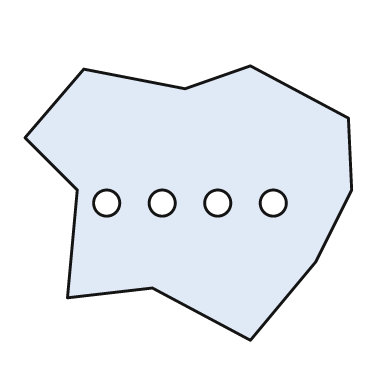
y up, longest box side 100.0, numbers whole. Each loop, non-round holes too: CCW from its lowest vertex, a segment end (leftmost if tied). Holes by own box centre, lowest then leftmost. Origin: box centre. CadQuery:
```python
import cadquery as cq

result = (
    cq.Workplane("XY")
    .moveTo(19.0, -42.0)
    .lineTo(39.0, -18.0)
    .lineTo(50.0, 4.0)
    .lineTo(49.0, 26.0)
    .lineTo(19.0, 42.0)
    .lineTo(-1.0, 35.0)
    .lineTo(-32.0, 41.0)
    .lineTo(-50.0, 20.0)
    .lineTo(-34.0, 4.0)
    .lineTo(-37.0, -29.0)
    .lineTo(-11.0, -26.0)
    .close()
    .moveTo(-25.0, 0.0)
    .circle(4.0)
    .moveTo(-8.0, 0.0)
    .circle(4.0)
    .moveTo(9.0, 0.0)
    .circle(4.0)
    .moveTo(26.0, 0.0)
    .circle(4.0)
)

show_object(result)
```